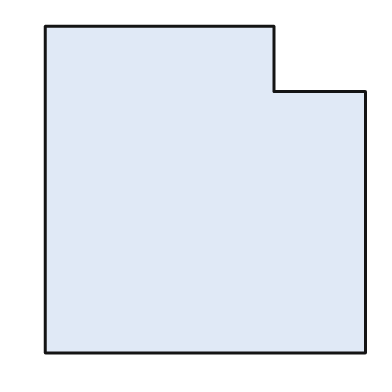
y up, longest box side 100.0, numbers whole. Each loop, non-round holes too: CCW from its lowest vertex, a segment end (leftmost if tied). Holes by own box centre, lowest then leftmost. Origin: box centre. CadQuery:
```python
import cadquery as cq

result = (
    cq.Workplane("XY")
    .moveTo(-49.0, -50.0)
    .lineTo(49.0, -50.0)
    .lineTo(49.0, 30.0)
    .lineTo(21.0, 30.0)
    .lineTo(21.0, 50.0)
    .lineTo(-49.0, 50.0)
    .close()
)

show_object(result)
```